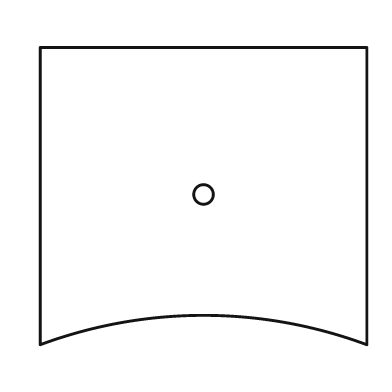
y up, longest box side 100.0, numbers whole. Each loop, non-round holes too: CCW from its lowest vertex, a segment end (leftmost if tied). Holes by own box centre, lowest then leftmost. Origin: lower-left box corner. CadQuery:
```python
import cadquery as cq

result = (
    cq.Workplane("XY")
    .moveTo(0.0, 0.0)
    .threePointArc((50.0, 9.0), (100.0, 0.0))
    .lineTo(100.0, 91.0)
    .lineTo(0.0, 91.0)
    .close()
    .moveTo(50.0, 46.0)
    .circle(3.0)
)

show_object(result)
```